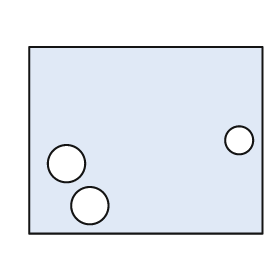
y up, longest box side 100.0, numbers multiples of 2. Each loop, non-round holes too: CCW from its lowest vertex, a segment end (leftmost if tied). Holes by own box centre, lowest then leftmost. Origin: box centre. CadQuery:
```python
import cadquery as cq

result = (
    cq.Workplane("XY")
    .moveTo(-50.0, -40.0)
    .lineTo(50.0, -40.0)
    .lineTo(50.0, 40.0)
    .lineTo(-50.0, 40.0)
    .close()
    .moveTo(-24.0, -28.0)
    .circle(8.0)
    .moveTo(-34.0, -10.0)
    .circle(8.0)
    .moveTo(40.0, 0.0)
    .circle(6.0)
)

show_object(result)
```